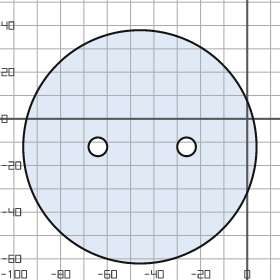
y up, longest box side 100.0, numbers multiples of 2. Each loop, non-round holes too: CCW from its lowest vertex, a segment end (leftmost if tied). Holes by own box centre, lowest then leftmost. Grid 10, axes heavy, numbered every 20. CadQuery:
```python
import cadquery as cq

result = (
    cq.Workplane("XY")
    .moveTo(-46.0, -12.0)
    .circle(50.0)
    .moveTo(-64.0, -12.0)
    .circle(4.0)
    .moveTo(-26.0, -12.0)
    .circle(4.0)
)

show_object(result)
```